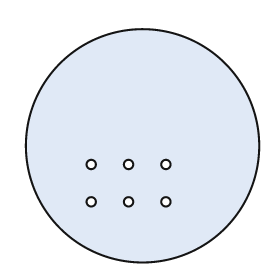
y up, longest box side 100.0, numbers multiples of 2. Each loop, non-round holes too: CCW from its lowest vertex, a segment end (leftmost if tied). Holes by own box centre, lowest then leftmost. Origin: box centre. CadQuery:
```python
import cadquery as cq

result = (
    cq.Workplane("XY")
    .moveTo(0.0, 0.0)
    .circle(50.0)
    .moveTo(-22.0, -24.0)
    .circle(2.0)
    .moveTo(-6.0, -24.0)
    .circle(2.0)
    .moveTo(10.0, -24.0)
    .circle(2.0)
    .moveTo(-22.0, -8.0)
    .circle(2.0)
    .moveTo(-6.0, -8.0)
    .circle(2.0)
    .moveTo(10.0, -8.0)
    .circle(2.0)
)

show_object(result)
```